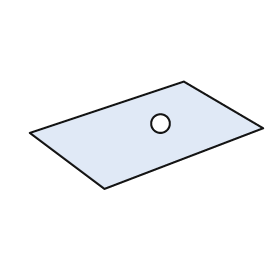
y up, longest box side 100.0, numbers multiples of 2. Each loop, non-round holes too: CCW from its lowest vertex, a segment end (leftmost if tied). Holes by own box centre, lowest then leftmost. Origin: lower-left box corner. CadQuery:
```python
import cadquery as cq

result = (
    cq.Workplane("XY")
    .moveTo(32.0, 0.0)
    .lineTo(100.0, 26.0)
    .lineTo(66.0, 46.0)
    .lineTo(0.0, 24.0)
    .close()
    .moveTo(56.0, 28.0)
    .circle(4.0)
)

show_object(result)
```